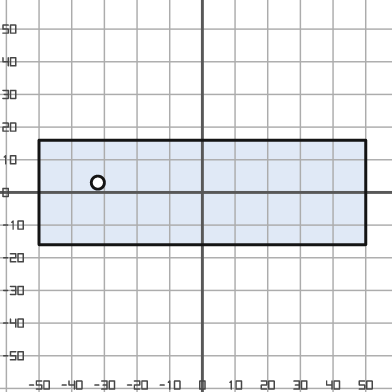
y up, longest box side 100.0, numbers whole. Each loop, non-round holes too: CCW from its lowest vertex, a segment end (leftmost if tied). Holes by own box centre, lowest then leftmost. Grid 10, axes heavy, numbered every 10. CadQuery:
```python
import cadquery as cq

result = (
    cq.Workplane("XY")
    .moveTo(-50.0, -16.0)
    .lineTo(50.0, -16.0)
    .lineTo(50.0, 16.0)
    .lineTo(-50.0, 16.0)
    .close()
    .moveTo(-32.0, 3.0)
    .circle(2.0)
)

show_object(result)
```